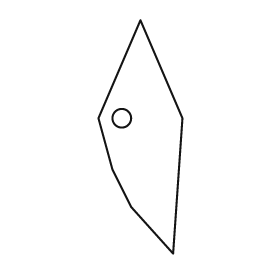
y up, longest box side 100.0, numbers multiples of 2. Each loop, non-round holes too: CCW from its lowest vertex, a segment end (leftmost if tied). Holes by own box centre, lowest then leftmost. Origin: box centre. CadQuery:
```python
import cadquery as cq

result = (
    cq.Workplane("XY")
    .moveTo(14.0, -50.0)
    .lineTo(18.0, 8.0)
    .lineTo(0.0, 50.0)
    .lineTo(-18.0, 8.0)
    .lineTo(-12.0, -14.0)
    .lineTo(-4.0, -30.0)
    .close()
    .moveTo(-8.0, 8.0)
    .circle(4.0)
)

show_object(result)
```